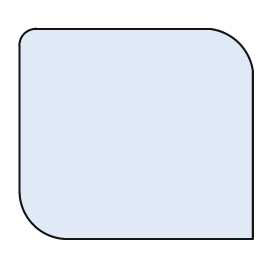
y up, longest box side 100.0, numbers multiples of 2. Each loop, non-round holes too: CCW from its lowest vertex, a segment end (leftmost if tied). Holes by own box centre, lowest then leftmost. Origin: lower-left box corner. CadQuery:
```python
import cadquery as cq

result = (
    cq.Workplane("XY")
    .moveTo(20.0, 0.0)
    .lineTo(100.0, 0.0)
    .lineTo(100.0, 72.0)
    .threePointArc((94.0, 84.0), (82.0, 90.0))
    .lineTo(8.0, 90.0)
    .threePointArc((2.0, 88.0), (0.0, 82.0))
    .lineTo(0.0, 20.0)
    .threePointArc((6.0, 6.0), (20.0, 0.0))
    .close()
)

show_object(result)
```